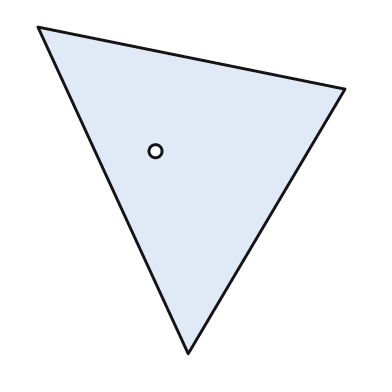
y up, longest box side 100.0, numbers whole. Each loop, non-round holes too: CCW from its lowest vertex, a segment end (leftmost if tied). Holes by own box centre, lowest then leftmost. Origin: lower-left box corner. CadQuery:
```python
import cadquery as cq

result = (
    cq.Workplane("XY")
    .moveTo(46.0, 0.0)
    .lineTo(94.0, 81.0)
    .lineTo(0.0, 100.0)
    .close()
    .moveTo(36.0, 62.0)
    .circle(2.0)
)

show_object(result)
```